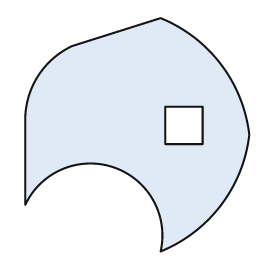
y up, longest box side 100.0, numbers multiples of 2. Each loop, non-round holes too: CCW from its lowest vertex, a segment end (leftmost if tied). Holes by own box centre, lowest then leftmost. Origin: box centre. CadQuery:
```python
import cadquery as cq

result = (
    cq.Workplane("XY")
    .moveTo(10.0, -50.0)
    .threePointArc((36.0, -30.0), (48.0, 0.0))
    .threePointArc((36.0, 30.0), (10.0, 50.0))
    .lineTo(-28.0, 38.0)
    .threePointArc((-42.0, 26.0), (-48.0, 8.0))
    .lineTo(-48.0, -30.0)
    .threePointArc((-10.0, -14.0), (10.0, -50.0))
    .close()
    .moveTo(12.0, -4.0)
    .lineTo(28.0, -4.0)
    .lineTo(28.0, 12.0)
    .lineTo(12.0, 12.0)
    .close()
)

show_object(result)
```